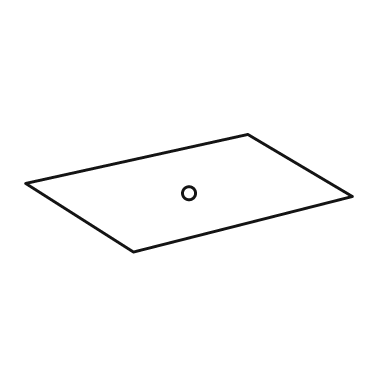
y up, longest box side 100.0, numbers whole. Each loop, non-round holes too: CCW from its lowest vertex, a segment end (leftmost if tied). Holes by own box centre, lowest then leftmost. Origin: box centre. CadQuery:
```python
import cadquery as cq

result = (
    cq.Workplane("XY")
    .moveTo(-17.0, -18.0)
    .lineTo(50.0, -1.0)
    .lineTo(18.0, 18.0)
    .lineTo(-50.0, 3.0)
    .close()
    .moveTo(0.0, 0.0)
    .circle(2.0)
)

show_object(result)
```